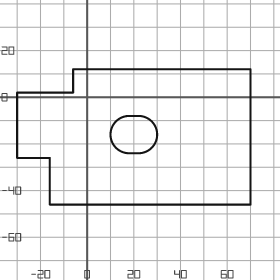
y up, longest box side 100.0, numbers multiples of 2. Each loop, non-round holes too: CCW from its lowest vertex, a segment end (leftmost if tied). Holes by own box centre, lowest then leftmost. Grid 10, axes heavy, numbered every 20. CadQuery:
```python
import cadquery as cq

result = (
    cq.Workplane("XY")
    .moveTo(-16.0, -46.0)
    .lineTo(70.0, -46.0)
    .lineTo(70.0, 12.0)
    .lineTo(-6.0, 12.0)
    .lineTo(-6.0, 2.0)
    .lineTo(-30.0, 2.0)
    .lineTo(-30.0, -26.0)
    .lineTo(-16.0, -26.0)
    .close()
    .moveTo(18.0, -24.0)
    .lineTo(22.0, -24.0)
    .threePointArc((30.0, -16.0), (22.0, -8.0))
    .lineTo(18.0, -8.0)
    .threePointArc((10.0, -16.0), (18.0, -24.0))
    .close()
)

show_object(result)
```